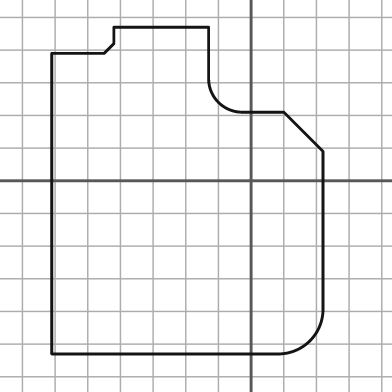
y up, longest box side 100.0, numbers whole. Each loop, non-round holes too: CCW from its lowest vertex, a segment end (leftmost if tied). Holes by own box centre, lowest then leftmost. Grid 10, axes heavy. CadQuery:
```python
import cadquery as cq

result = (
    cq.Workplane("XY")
    .moveTo(-61.0, -53.0)
    .lineTo(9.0, -53.0)
    .threePointArc((18.0, -49.0), (22.0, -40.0))
    .lineTo(22.0, 9.0)
    .lineTo(10.0, 21.0)
    .lineTo(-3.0, 21.0)
    .threePointArc((-10.0, 24.0), (-13.0, 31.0))
    .lineTo(-13.0, 47.0)
    .lineTo(-42.0, 47.0)
    .lineTo(-42.0, 42.0)
    .lineTo(-45.0, 39.0)
    .lineTo(-61.0, 39.0)
    .close()
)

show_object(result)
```